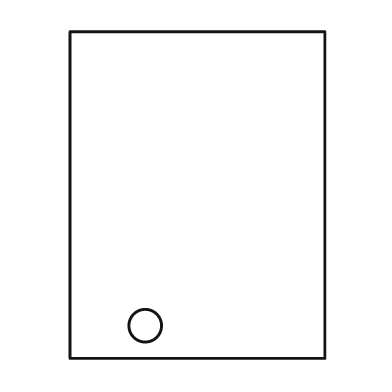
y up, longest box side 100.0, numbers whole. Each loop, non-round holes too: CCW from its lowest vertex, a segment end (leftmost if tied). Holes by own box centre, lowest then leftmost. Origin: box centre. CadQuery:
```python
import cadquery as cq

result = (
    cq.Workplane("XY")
    .moveTo(-39.0, -50.0)
    .lineTo(39.0, -50.0)
    .lineTo(39.0, 50.0)
    .lineTo(-39.0, 50.0)
    .close()
    .moveTo(-16.0, -40.0)
    .circle(5.0)
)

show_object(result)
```